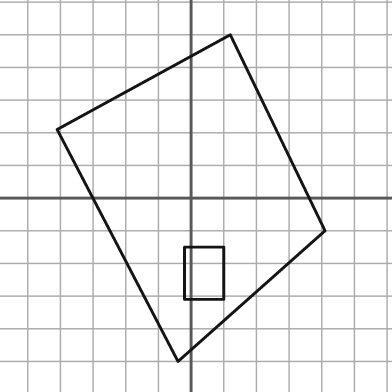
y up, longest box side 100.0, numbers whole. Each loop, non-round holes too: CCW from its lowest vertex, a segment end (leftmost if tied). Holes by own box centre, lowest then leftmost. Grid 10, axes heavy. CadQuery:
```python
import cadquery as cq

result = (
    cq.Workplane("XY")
    .moveTo(-4.0, -50.0)
    .lineTo(41.0, -10.0)
    .lineTo(12.0, 50.0)
    .lineTo(-41.0, 21.0)
    .close()
    .moveTo(-2.0, -31.0)
    .lineTo(10.0, -31.0)
    .lineTo(10.0, -15.0)
    .lineTo(-2.0, -15.0)
    .close()
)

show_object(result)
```